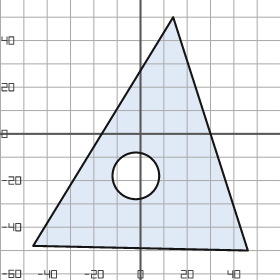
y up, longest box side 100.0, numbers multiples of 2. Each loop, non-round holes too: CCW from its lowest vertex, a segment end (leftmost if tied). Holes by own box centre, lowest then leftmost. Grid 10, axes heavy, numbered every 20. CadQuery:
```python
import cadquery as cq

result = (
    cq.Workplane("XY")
    .moveTo(46.0, -50.0)
    .lineTo(14.0, 50.0)
    .lineTo(-46.0, -48.0)
    .close()
    .moveTo(-2.0, -18.0)
    .circle(10.0)
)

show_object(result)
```